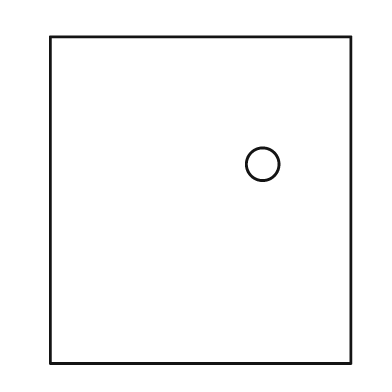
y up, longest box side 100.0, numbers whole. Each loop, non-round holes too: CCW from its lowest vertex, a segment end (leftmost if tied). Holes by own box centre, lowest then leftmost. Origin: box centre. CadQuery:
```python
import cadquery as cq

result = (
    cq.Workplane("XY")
    .moveTo(-46.0, -50.0)
    .lineTo(46.0, -50.0)
    .lineTo(46.0, 50.0)
    .lineTo(-46.0, 50.0)
    .close()
    .moveTo(19.0, 11.0)
    .circle(5.0)
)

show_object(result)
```